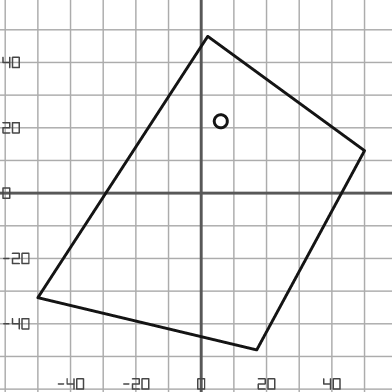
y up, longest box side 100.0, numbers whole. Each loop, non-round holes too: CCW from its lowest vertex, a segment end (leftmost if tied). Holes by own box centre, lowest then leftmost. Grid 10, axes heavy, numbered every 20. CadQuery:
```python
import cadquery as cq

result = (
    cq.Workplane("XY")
    .moveTo(17.0, -48.0)
    .lineTo(50.0, 13.0)
    .lineTo(2.0, 48.0)
    .lineTo(-50.0, -32.0)
    .close()
    .moveTo(6.0, 22.0)
    .circle(2.0)
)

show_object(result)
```